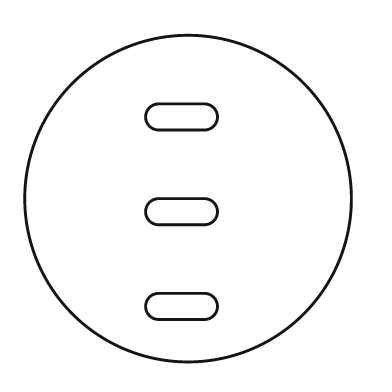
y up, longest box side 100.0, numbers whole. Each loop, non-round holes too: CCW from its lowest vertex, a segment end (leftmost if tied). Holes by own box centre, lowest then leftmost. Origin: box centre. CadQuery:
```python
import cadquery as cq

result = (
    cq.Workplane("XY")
    .moveTo(0.0, 0.0)
    .circle(50.0)
    .moveTo(-9.0, -37.0)
    .lineTo(5.0, -37.0)
    .threePointArc((9.0, -33.0), (5.0, -29.0))
    .lineTo(-9.0, -29.0)
    .threePointArc((-13.0, -33.0), (-9.0, -37.0))
    .close()
    .moveTo(-9.0, -8.0)
    .lineTo(5.0, -8.0)
    .threePointArc((9.0, -4.0), (5.0, 0.0))
    .lineTo(-9.0, 0.0)
    .threePointArc((-13.0, -4.0), (-9.0, -8.0))
    .close()
    .moveTo(-9.0, 21.0)
    .lineTo(5.0, 21.0)
    .threePointArc((9.0, 25.0), (5.0, 29.0))
    .lineTo(-9.0, 29.0)
    .threePointArc((-13.0, 25.0), (-9.0, 21.0))
    .close()
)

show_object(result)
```